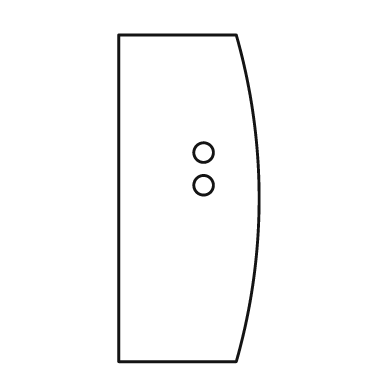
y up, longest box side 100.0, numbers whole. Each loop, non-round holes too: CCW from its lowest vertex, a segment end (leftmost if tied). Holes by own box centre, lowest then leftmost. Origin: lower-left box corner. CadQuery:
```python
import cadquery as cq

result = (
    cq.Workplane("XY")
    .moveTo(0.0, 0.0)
    .lineTo(36.0, 0.0)
    .threePointArc((43.0, 50.0), (36.0, 100.0))
    .lineTo(0.0, 100.0)
    .close()
    .moveTo(26.0, 54.0)
    .circle(3.0)
    .moveTo(26.0, 64.0)
    .circle(3.0)
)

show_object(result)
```